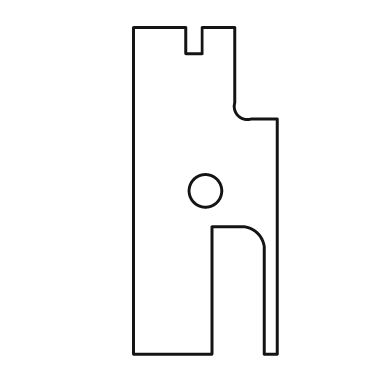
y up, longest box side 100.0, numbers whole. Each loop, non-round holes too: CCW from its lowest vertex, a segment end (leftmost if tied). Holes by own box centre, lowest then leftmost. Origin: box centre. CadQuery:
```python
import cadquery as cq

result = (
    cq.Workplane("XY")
    .moveTo(-22.0, -50.0)
    .lineTo(2.0, -50.0)
    .lineTo(2.0, -11.0)
    .lineTo(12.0, -11.0)
    .threePointArc((16.0, -13.0), (18.0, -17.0))
    .lineTo(18.0, -50.0)
    .lineTo(22.0, -50.0)
    .lineTo(22.0, 22.0)
    .lineTo(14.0, 22.0)
    .threePointArc((10.0, 23.0), (9.0, 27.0))
    .lineTo(9.0, 50.0)
    .lineTo(-1.0, 50.0)
    .lineTo(-1.0, 42.0)
    .lineTo(-6.0, 42.0)
    .lineTo(-6.0, 50.0)
    .lineTo(-22.0, 50.0)
    .close()
    .moveTo(0.0, 0.0)
    .circle(5.0)
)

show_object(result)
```